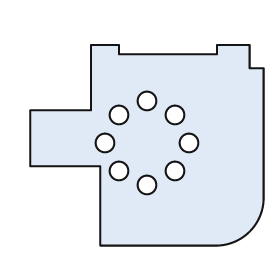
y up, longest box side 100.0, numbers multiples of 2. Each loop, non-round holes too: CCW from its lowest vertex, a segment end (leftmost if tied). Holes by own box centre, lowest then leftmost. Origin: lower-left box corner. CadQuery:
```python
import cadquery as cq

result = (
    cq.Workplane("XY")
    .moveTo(30.0, 0.0)
    .lineTo(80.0, 0.0)
    .threePointArc((94.0, 6.0), (100.0, 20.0))
    .lineTo(100.0, 76.0)
    .lineTo(94.0, 76.0)
    .lineTo(94.0, 86.0)
    .lineTo(80.0, 86.0)
    .lineTo(80.0, 82.0)
    .lineTo(38.0, 82.0)
    .lineTo(38.0, 86.0)
    .lineTo(26.0, 86.0)
    .lineTo(26.0, 58.0)
    .lineTo(0.0, 58.0)
    .lineTo(0.0, 34.0)
    .lineTo(30.0, 34.0)
    .close()
    .moveTo(50.0, 26.0)
    .circle(4.0)
    .moveTo(38.0, 32.0)
    .circle(4.0)
    .moveTo(62.0, 32.0)
    .circle(4.0)
    .moveTo(32.0, 44.0)
    .circle(4.0)
    .moveTo(68.0, 44.0)
    .circle(4.0)
    .moveTo(38.0, 56.0)
    .circle(4.0)
    .moveTo(62.0, 56.0)
    .circle(4.0)
    .moveTo(50.0, 62.0)
    .circle(4.0)
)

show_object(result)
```